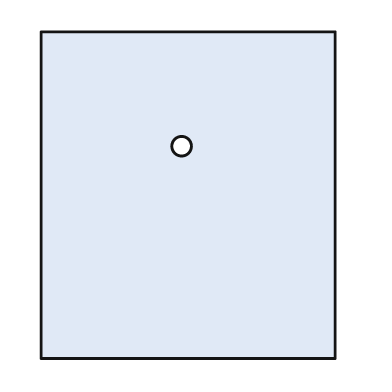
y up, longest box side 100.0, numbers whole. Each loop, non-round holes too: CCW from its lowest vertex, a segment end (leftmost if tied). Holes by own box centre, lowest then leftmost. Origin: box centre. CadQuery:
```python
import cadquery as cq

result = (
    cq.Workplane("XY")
    .moveTo(-45.0, -50.0)
    .lineTo(45.0, -50.0)
    .lineTo(45.0, 50.0)
    .lineTo(-45.0, 50.0)
    .close()
    .moveTo(-2.0, 15.0)
    .circle(3.0)
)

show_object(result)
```